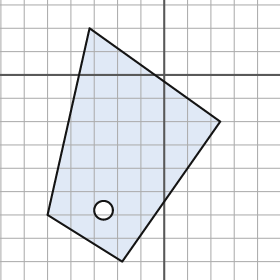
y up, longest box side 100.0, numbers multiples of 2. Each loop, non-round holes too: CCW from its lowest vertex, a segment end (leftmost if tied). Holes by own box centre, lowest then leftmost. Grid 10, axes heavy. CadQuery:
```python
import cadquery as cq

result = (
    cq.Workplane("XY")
    .moveTo(-18.0, -80.0)
    .lineTo(24.0, -20.0)
    .lineTo(-32.0, 20.0)
    .lineTo(-50.0, -60.0)
    .close()
    .moveTo(-26.0, -58.0)
    .circle(4.0)
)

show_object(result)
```